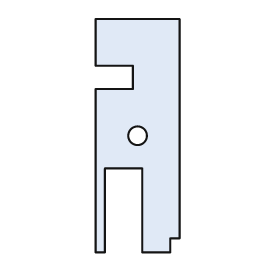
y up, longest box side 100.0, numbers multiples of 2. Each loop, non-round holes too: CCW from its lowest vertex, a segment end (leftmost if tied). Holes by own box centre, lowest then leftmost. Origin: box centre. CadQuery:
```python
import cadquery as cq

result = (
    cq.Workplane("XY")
    .moveTo(-18.0, -50.0)
    .lineTo(-14.0, -50.0)
    .lineTo(-14.0, -14.0)
    .lineTo(2.0, -14.0)
    .lineTo(2.0, -50.0)
    .lineTo(14.0, -50.0)
    .lineTo(14.0, -44.0)
    .lineTo(18.0, -44.0)
    .lineTo(18.0, 50.0)
    .lineTo(-18.0, 50.0)
    .lineTo(-18.0, 30.0)
    .lineTo(-2.0, 30.0)
    .lineTo(-2.0, 20.0)
    .lineTo(-18.0, 20.0)
    .close()
    .moveTo(0.0, 0.0)
    .circle(4.0)
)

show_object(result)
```